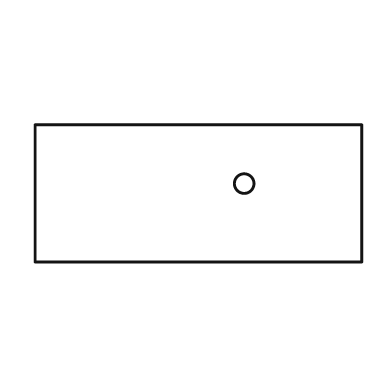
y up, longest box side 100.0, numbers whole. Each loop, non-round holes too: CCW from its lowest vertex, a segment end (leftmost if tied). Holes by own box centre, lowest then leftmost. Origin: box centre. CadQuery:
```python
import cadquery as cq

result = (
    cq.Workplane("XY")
    .moveTo(-50.0, -21.0)
    .lineTo(50.0, -21.0)
    .lineTo(50.0, 21.0)
    .lineTo(-50.0, 21.0)
    .close()
    .moveTo(14.0, 3.0)
    .circle(3.0)
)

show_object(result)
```